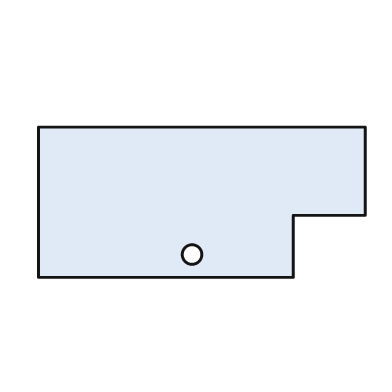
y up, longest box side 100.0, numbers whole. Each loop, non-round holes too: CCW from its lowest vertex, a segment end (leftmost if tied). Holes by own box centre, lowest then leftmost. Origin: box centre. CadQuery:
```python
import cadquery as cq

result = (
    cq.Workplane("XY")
    .moveTo(-50.0, -23.0)
    .lineTo(28.0, -23.0)
    .lineTo(28.0, -4.0)
    .lineTo(50.0, -4.0)
    .lineTo(50.0, 23.0)
    .lineTo(-50.0, 23.0)
    .close()
    .moveTo(-3.0, -16.0)
    .circle(3.0)
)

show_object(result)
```